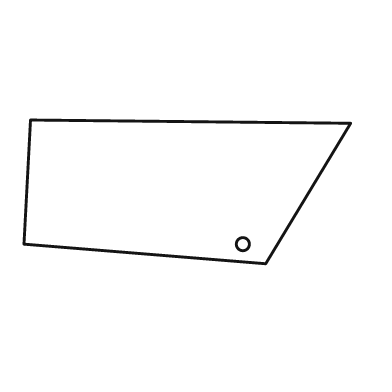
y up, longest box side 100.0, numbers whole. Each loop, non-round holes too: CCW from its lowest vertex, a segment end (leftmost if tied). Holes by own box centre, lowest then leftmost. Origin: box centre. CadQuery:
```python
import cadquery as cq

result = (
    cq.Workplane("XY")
    .moveTo(24.0, -22.0)
    .lineTo(50.0, 21.0)
    .lineTo(-48.0, 22.0)
    .lineTo(-50.0, -16.0)
    .close()
    .moveTo(17.0, -16.0)
    .circle(2.0)
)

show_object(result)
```